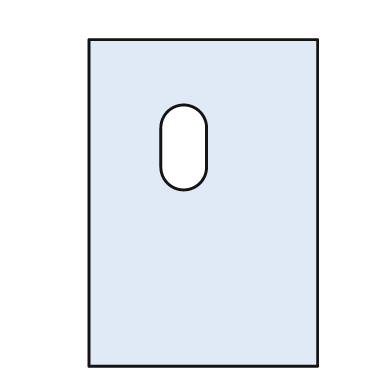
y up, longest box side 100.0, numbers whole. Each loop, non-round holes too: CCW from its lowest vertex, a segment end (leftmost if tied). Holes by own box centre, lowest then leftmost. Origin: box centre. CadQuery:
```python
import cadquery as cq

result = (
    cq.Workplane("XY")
    .moveTo(-35.0, -50.0)
    .lineTo(35.0, -50.0)
    .lineTo(35.0, 50.0)
    .lineTo(-35.0, 50.0)
    .close()
    .moveTo(-13.0, 11.0)
    .threePointArc((-6.0, 4.0), (1.0, 11.0))
    .lineTo(1.0, 23.0)
    .threePointArc((-6.0, 30.0), (-13.0, 23.0))
    .close()
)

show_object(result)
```